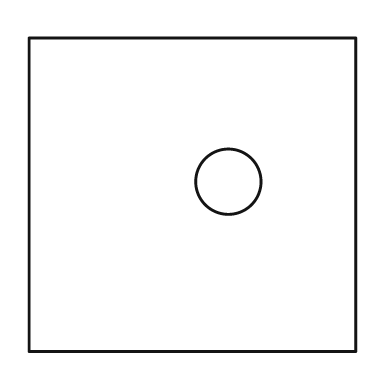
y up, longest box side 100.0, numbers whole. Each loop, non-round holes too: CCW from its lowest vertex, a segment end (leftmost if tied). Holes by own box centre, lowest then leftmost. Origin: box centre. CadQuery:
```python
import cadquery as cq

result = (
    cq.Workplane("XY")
    .moveTo(-50.0, -48.0)
    .lineTo(50.0, -48.0)
    .lineTo(50.0, 48.0)
    .lineTo(-50.0, 48.0)
    .close()
    .moveTo(11.0, 4.0)
    .circle(10.0)
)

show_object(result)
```